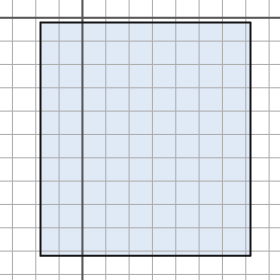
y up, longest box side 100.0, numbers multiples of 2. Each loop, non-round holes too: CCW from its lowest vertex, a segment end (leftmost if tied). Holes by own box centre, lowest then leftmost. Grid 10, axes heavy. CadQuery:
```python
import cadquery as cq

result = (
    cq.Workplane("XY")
    .moveTo(-18.0, -102.0)
    .lineTo(72.0, -102.0)
    .lineTo(72.0, -2.0)
    .lineTo(-18.0, -2.0)
    .close()
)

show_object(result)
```